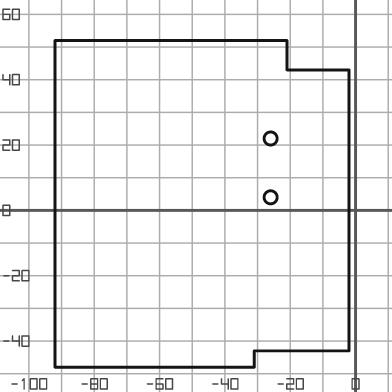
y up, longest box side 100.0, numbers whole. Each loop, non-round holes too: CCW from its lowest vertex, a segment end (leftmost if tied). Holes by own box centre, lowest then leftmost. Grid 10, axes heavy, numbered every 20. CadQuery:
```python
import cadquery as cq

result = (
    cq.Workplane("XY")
    .moveTo(-92.0, -48.0)
    .lineTo(-31.0, -48.0)
    .lineTo(-31.0, -43.0)
    .lineTo(-2.0, -43.0)
    .lineTo(-2.0, 43.0)
    .lineTo(-21.0, 43.0)
    .lineTo(-21.0, 52.0)
    .lineTo(-92.0, 52.0)
    .close()
    .moveTo(-26.0, 4.0)
    .circle(2.0)
    .moveTo(-26.0, 22.0)
    .circle(2.0)
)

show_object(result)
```